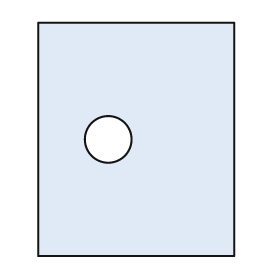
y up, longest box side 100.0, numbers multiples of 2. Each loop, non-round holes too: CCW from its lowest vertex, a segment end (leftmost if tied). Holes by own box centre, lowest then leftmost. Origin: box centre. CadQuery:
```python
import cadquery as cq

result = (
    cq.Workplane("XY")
    .moveTo(-42.0, -50.0)
    .lineTo(42.0, -50.0)
    .lineTo(42.0, 50.0)
    .lineTo(-42.0, 50.0)
    .close()
    .moveTo(-12.0, 0.0)
    .circle(10.0)
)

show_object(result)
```